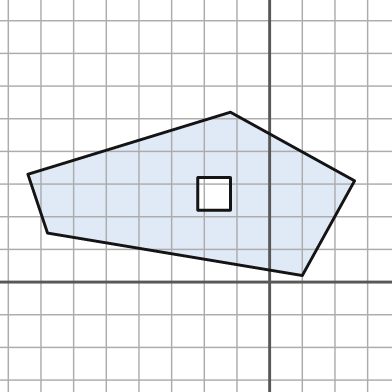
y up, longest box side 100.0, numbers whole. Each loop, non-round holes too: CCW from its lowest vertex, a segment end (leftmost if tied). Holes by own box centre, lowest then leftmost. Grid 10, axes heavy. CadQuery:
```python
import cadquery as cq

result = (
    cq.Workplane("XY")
    .moveTo(10.0, 2.0)
    .lineTo(26.0, 31.0)
    .lineTo(-12.0, 52.0)
    .lineTo(-74.0, 33.0)
    .lineTo(-68.0, 15.0)
    .close()
    .moveTo(-22.0, 22.0)
    .lineTo(-12.0, 22.0)
    .lineTo(-12.0, 32.0)
    .lineTo(-22.0, 32.0)
    .close()
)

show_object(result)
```